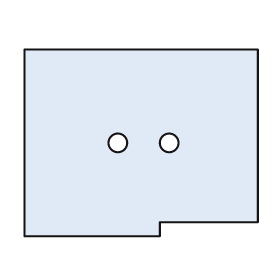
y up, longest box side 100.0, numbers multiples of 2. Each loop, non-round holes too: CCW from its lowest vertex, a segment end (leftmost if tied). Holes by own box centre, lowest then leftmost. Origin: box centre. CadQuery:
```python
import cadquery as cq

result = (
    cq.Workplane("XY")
    .moveTo(-50.0, -40.0)
    .lineTo(8.0, -40.0)
    .lineTo(8.0, -34.0)
    .lineTo(50.0, -34.0)
    .lineTo(50.0, 40.0)
    .lineTo(-50.0, 40.0)
    .close()
    .moveTo(-10.0, 0.0)
    .circle(4.0)
    .moveTo(12.0, 0.0)
    .circle(4.0)
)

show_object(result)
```